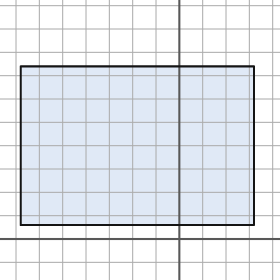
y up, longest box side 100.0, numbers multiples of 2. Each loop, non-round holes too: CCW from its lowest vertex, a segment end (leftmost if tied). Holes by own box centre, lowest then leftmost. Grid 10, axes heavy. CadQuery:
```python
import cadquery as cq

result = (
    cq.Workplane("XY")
    .moveTo(-68.0, 6.0)
    .lineTo(32.0, 6.0)
    .lineTo(32.0, 74.0)
    .lineTo(-68.0, 74.0)
    .close()
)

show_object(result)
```